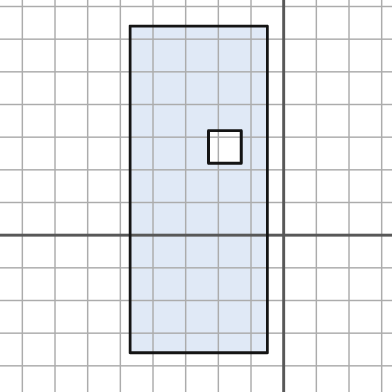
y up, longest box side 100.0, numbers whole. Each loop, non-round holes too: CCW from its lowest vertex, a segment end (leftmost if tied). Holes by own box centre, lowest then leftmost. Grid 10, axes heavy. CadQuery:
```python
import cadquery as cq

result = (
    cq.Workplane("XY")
    .moveTo(-47.0, -36.0)
    .lineTo(-5.0, -36.0)
    .lineTo(-5.0, 64.0)
    .lineTo(-47.0, 64.0)
    .close()
    .moveTo(-23.0, 22.0)
    .lineTo(-13.0, 22.0)
    .lineTo(-13.0, 32.0)
    .lineTo(-23.0, 32.0)
    .close()
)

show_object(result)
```